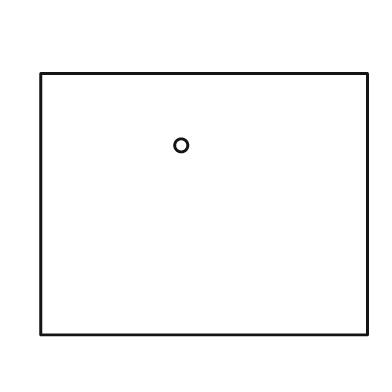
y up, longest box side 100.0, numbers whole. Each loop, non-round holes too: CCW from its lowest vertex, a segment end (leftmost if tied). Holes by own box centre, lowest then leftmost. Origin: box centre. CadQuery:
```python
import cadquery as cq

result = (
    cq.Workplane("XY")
    .moveTo(-50.0, -40.0)
    .lineTo(50.0, -40.0)
    .lineTo(50.0, 40.0)
    .lineTo(-50.0, 40.0)
    .close()
    .moveTo(-7.0, 18.0)
    .circle(2.0)
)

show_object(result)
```